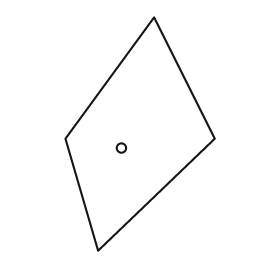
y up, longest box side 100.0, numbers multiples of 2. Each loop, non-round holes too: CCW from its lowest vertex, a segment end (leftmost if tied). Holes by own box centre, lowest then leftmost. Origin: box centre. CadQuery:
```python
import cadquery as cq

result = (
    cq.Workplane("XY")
    .moveTo(-18.0, -50.0)
    .lineTo(32.0, -2.0)
    .lineTo(6.0, 50.0)
    .lineTo(-32.0, -2.0)
    .close()
    .moveTo(-8.0, -6.0)
    .circle(2.0)
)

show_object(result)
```